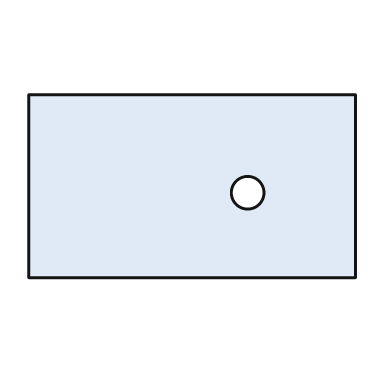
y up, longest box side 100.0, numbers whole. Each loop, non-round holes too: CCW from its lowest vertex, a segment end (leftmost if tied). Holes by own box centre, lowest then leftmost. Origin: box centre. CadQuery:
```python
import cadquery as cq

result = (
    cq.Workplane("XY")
    .moveTo(-50.0, -28.0)
    .lineTo(50.0, -28.0)
    .lineTo(50.0, 28.0)
    .lineTo(-50.0, 28.0)
    .close()
    .moveTo(17.0, -2.0)
    .circle(5.0)
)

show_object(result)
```